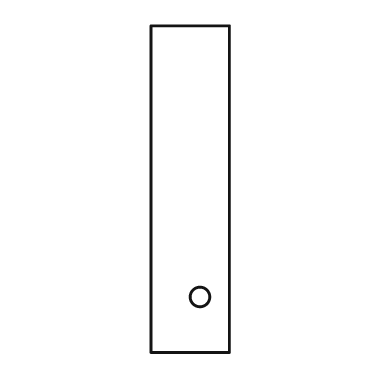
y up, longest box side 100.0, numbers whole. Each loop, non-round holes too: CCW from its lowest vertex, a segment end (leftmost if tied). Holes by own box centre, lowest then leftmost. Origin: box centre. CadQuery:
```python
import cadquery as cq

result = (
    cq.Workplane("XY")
    .moveTo(-12.0, -50.0)
    .lineTo(12.0, -50.0)
    .lineTo(12.0, 50.0)
    .lineTo(-12.0, 50.0)
    .close()
    .moveTo(3.0, -33.0)
    .circle(3.0)
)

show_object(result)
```